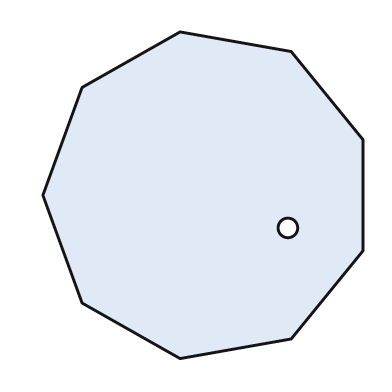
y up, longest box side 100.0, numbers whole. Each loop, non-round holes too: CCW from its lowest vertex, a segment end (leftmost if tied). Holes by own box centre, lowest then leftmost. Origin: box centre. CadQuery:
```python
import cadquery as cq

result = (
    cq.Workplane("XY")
    .moveTo(-7.0, -50.0)
    .lineTo(27.0, -44.0)
    .lineTo(49.0, -17.0)
    .lineTo(49.0, 17.0)
    .lineTo(27.0, 44.0)
    .lineTo(-7.0, 50.0)
    .lineTo(-37.0, 33.0)
    .lineTo(-49.0, 0.0)
    .lineTo(-37.0, -33.0)
    .close()
    .moveTo(26.0, -10.0)
    .circle(3.0)
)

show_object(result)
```